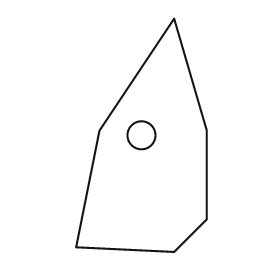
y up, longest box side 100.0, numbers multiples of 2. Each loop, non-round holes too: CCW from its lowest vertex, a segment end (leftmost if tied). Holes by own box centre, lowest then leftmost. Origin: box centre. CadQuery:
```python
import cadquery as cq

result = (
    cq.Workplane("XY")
    .moveTo(14.0, -50.0)
    .lineTo(28.0, -36.0)
    .lineTo(28.0, 2.0)
    .lineTo(14.0, 50.0)
    .lineTo(-18.0, 2.0)
    .lineTo(-28.0, -48.0)
    .close()
    .moveTo(0.0, 0.0)
    .circle(6.0)
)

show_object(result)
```